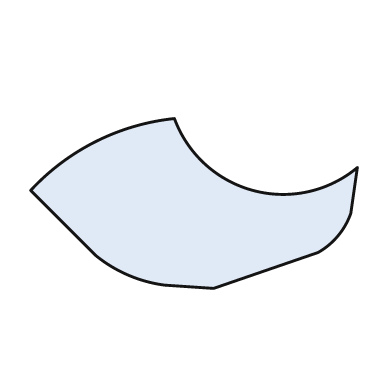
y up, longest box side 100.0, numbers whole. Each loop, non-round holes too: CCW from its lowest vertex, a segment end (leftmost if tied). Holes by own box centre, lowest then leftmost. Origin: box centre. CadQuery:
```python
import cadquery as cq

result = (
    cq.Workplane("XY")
    .moveTo(6.0, -26.0)
    .lineTo(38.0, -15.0)
    .threePointArc((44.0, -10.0), (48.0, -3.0))
    .lineTo(50.0, 11.0)
    .threePointArc((18.0, 4.0), (-6.0, 26.0))
    .threePointArc((-30.0, 19.0), (-50.0, 4.0))
    .lineTo(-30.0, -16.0)
    .threePointArc((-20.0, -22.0), (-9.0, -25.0))
    .close()
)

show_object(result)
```